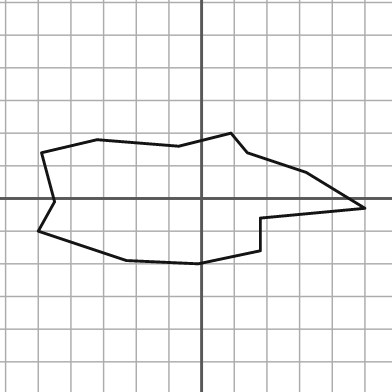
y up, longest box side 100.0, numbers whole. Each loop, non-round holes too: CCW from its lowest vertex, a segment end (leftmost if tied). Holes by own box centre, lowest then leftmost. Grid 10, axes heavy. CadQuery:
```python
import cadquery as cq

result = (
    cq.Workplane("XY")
    .moveTo(-1.0, -20.0)
    .lineTo(18.0, -16.0)
    .lineTo(18.0, -6.0)
    .lineTo(50.0, -3.0)
    .lineTo(32.0, 8.0)
    .lineTo(14.0, 14.0)
    .lineTo(9.0, 20.0)
    .lineTo(-7.0, 16.0)
    .lineTo(-32.0, 18.0)
    .lineTo(-49.0, 14.0)
    .lineTo(-45.0, -1.0)
    .lineTo(-50.0, -10.0)
    .lineTo(-23.0, -19.0)
    .close()
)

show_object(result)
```